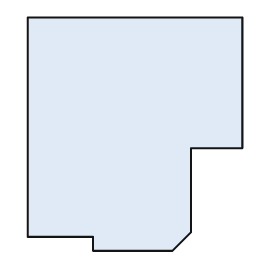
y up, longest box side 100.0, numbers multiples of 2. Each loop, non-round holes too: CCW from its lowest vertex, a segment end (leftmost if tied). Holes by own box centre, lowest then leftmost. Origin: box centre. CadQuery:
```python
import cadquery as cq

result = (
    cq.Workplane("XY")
    .moveTo(-18.0, -50.0)
    .lineTo(16.0, -50.0)
    .lineTo(24.0, -42.0)
    .lineTo(24.0, -6.0)
    .lineTo(46.0, -6.0)
    .lineTo(46.0, 50.0)
    .lineTo(-46.0, 50.0)
    .lineTo(-46.0, -44.0)
    .lineTo(-18.0, -44.0)
    .close()
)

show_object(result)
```